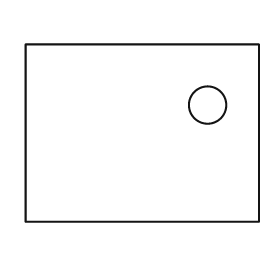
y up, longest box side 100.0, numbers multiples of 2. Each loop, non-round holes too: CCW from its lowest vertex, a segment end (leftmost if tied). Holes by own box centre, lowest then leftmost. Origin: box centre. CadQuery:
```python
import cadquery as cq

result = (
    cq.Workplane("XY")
    .moveTo(-50.0, -38.0)
    .lineTo(50.0, -38.0)
    .lineTo(50.0, 38.0)
    .lineTo(-50.0, 38.0)
    .close()
    .moveTo(28.0, 12.0)
    .circle(8.0)
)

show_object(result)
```